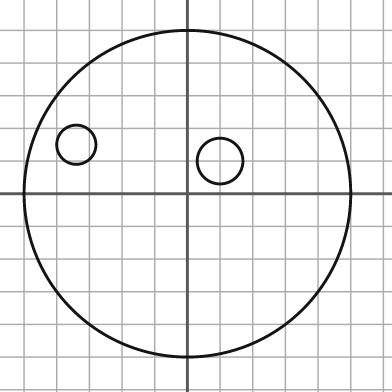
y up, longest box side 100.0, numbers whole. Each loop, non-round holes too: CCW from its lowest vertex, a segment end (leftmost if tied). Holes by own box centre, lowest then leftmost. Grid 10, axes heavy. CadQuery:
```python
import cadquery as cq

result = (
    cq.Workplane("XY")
    .moveTo(0.0, 0.0)
    .circle(50.0)
    .moveTo(10.0, 10.0)
    .circle(7.0)
    .moveTo(-34.0, 15.0)
    .circle(6.0)
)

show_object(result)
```